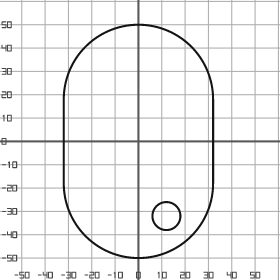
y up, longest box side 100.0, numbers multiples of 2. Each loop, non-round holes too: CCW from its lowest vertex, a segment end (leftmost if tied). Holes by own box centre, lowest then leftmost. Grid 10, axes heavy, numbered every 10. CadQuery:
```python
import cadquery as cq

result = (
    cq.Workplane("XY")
    .moveTo(-32.0, -18.0)
    .threePointArc((0.0, -50.0), (32.0, -18.0))
    .lineTo(32.0, 18.0)
    .threePointArc((0.0, 50.0), (-32.0, 18.0))
    .close()
    .moveTo(12.0, -32.0)
    .circle(6.0)
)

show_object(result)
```